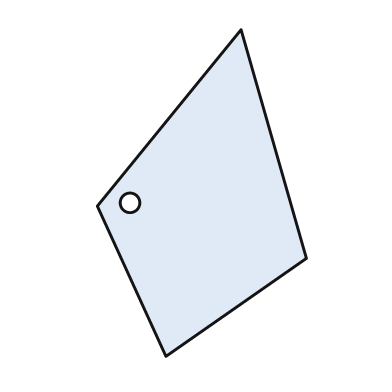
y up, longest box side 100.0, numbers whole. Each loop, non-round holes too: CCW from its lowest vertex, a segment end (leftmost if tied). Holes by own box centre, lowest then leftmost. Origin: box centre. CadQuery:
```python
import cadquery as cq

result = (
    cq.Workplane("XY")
    .moveTo(-11.0, -50.0)
    .lineTo(32.0, -20.0)
    .lineTo(12.0, 50.0)
    .lineTo(-32.0, -4.0)
    .close()
    .moveTo(-22.0, -3.0)
    .circle(3.0)
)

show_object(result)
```